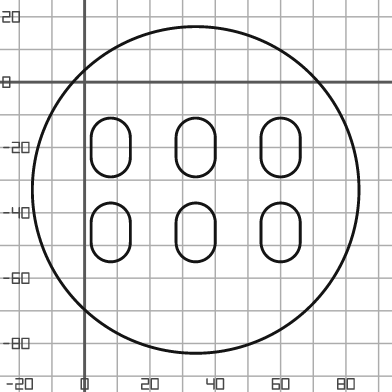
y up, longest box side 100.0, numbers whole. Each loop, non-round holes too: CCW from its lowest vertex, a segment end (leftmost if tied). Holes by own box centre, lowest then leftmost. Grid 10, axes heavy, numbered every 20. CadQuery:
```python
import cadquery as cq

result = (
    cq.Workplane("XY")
    .moveTo(34.0, -33.0)
    .circle(50.0)
    .moveTo(2.0, -49.0)
    .threePointArc((8.0, -55.0), (14.0, -49.0))
    .lineTo(14.0, -43.0)
    .threePointArc((8.0, -37.0), (2.0, -43.0))
    .close()
    .moveTo(28.0, -49.0)
    .threePointArc((34.0, -55.0), (40.0, -49.0))
    .lineTo(40.0, -43.0)
    .threePointArc((34.0, -37.0), (28.0, -43.0))
    .close()
    .moveTo(54.0, -49.0)
    .threePointArc((60.0, -55.0), (66.0, -49.0))
    .lineTo(66.0, -43.0)
    .threePointArc((60.0, -37.0), (54.0, -43.0))
    .close()
    .moveTo(2.0, -23.0)
    .threePointArc((8.0, -29.0), (14.0, -23.0))
    .lineTo(14.0, -17.0)
    .threePointArc((8.0, -11.0), (2.0, -17.0))
    .close()
    .moveTo(28.0, -23.0)
    .threePointArc((34.0, -29.0), (40.0, -23.0))
    .lineTo(40.0, -17.0)
    .threePointArc((34.0, -11.0), (28.0, -17.0))
    .close()
    .moveTo(54.0, -23.0)
    .threePointArc((60.0, -29.0), (66.0, -23.0))
    .lineTo(66.0, -17.0)
    .threePointArc((60.0, -11.0), (54.0, -17.0))
    .close()
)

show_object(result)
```